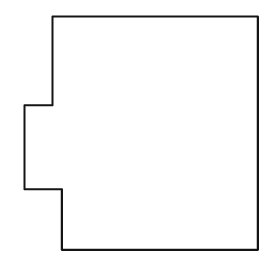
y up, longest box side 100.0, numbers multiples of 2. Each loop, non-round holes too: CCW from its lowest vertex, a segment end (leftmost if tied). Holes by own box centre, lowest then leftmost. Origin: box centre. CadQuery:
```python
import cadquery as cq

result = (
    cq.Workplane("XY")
    .moveTo(-34.0, -50.0)
    .lineTo(50.0, -50.0)
    .lineTo(50.0, 50.0)
    .lineTo(-38.0, 50.0)
    .lineTo(-38.0, 12.0)
    .lineTo(-50.0, 12.0)
    .lineTo(-50.0, -24.0)
    .lineTo(-34.0, -24.0)
    .close()
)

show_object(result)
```